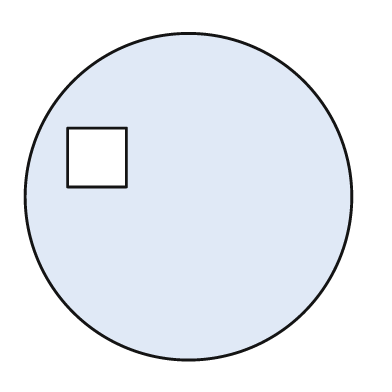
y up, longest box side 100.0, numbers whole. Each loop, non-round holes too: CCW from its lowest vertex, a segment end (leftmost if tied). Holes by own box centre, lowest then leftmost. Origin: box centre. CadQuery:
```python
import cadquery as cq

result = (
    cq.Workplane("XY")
    .moveTo(0.0, 0.0)
    .circle(50.0)
    .moveTo(-37.0, 3.0)
    .lineTo(-19.0, 3.0)
    .lineTo(-19.0, 21.0)
    .lineTo(-37.0, 21.0)
    .close()
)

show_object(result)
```